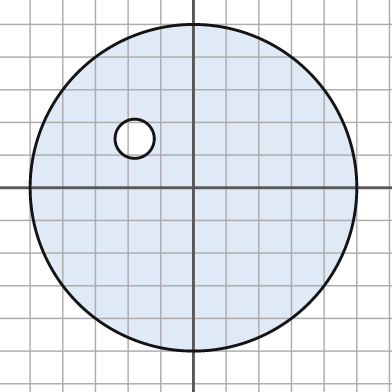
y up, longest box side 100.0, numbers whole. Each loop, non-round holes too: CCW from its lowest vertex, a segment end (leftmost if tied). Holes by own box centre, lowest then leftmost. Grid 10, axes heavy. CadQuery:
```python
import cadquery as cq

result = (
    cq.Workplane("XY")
    .moveTo(0.0, 0.0)
    .circle(50.0)
    .moveTo(-18.0, 15.0)
    .circle(6.0)
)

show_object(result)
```